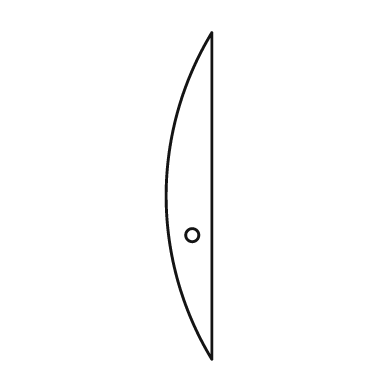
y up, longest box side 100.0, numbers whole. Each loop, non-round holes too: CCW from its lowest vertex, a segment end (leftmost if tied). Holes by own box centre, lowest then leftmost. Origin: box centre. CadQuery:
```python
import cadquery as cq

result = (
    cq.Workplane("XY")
    .moveTo(7.0, -50.0)
    .lineTo(7.0, 50.0)
    .threePointArc((-7.0, 0.0), (7.0, -50.0))
    .close()
    .moveTo(1.0, -12.0)
    .circle(2.0)
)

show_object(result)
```